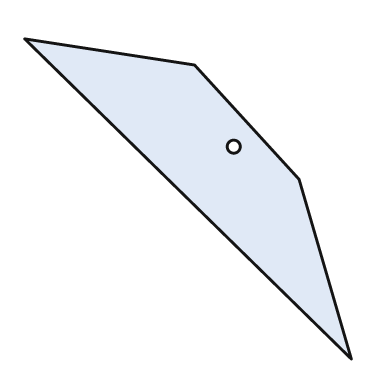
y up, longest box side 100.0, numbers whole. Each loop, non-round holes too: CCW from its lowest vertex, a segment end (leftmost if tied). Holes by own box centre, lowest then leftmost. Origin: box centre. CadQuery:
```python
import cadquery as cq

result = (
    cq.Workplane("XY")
    .moveTo(50.0, -49.0)
    .lineTo(34.0, 6.0)
    .lineTo(2.0, 41.0)
    .lineTo(-50.0, 49.0)
    .close()
    .moveTo(14.0, 16.0)
    .circle(2.0)
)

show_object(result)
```